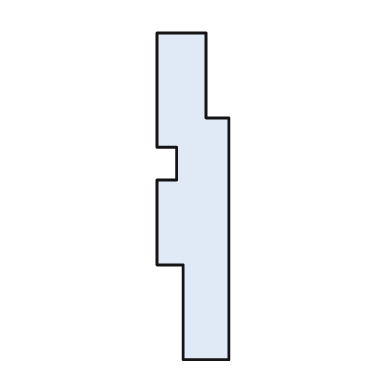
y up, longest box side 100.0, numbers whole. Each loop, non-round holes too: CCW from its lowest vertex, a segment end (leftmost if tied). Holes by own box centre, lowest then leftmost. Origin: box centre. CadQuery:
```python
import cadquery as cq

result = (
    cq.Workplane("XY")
    .moveTo(-3.0, -50.0)
    .lineTo(11.0, -50.0)
    .lineTo(11.0, 24.0)
    .lineTo(4.0, 24.0)
    .lineTo(4.0, 50.0)
    .lineTo(-11.0, 50.0)
    .lineTo(-11.0, 15.0)
    .lineTo(-5.0, 15.0)
    .lineTo(-5.0, 5.0)
    .lineTo(-11.0, 5.0)
    .lineTo(-11.0, -21.0)
    .lineTo(-3.0, -21.0)
    .close()
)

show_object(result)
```